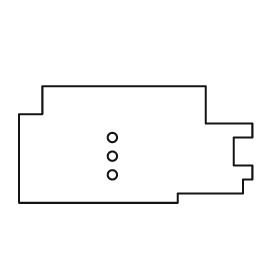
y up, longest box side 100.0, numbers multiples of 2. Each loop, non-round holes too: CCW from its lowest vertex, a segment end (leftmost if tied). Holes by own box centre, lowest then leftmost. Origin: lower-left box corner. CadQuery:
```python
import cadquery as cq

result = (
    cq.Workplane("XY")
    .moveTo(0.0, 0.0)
    .lineTo(68.0, 0.0)
    .lineTo(68.0, 4.0)
    .lineTo(96.0, 4.0)
    .lineTo(96.0, 10.0)
    .lineTo(100.0, 10.0)
    .lineTo(100.0, 16.0)
    .lineTo(92.0, 16.0)
    .lineTo(92.0, 28.0)
    .lineTo(100.0, 28.0)
    .lineTo(100.0, 34.0)
    .lineTo(80.0, 34.0)
    .lineTo(80.0, 50.0)
    .lineTo(10.0, 50.0)
    .lineTo(10.0, 38.0)
    .lineTo(0.0, 38.0)
    .close()
    .moveTo(40.0, 12.0)
    .circle(2.0)
    .moveTo(40.0, 20.0)
    .circle(2.0)
    .moveTo(40.0, 28.0)
    .circle(2.0)
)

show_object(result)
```